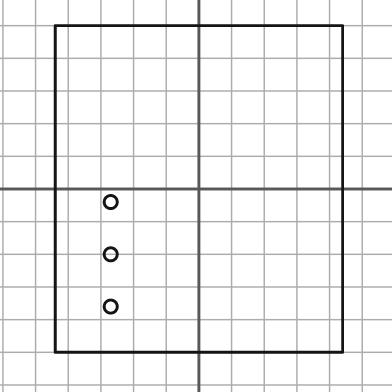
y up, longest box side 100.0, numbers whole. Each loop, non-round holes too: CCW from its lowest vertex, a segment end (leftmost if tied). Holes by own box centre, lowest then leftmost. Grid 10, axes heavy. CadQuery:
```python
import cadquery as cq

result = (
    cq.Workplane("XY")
    .moveTo(-44.0, -50.0)
    .lineTo(44.0, -50.0)
    .lineTo(44.0, 50.0)
    .lineTo(-44.0, 50.0)
    .close()
    .moveTo(-27.0, -36.0)
    .circle(2.0)
    .moveTo(-27.0, -20.0)
    .circle(2.0)
    .moveTo(-27.0, -4.0)
    .circle(2.0)
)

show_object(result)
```